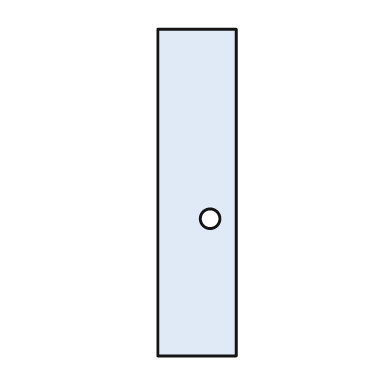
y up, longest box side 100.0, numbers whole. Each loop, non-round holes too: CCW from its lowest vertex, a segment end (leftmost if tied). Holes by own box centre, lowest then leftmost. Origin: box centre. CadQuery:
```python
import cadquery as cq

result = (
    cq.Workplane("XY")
    .moveTo(-12.0, -50.0)
    .lineTo(12.0, -50.0)
    .lineTo(12.0, 50.0)
    .lineTo(-12.0, 50.0)
    .close()
    .moveTo(4.0, -8.0)
    .circle(3.0)
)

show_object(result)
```